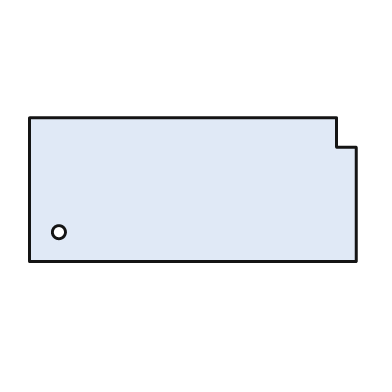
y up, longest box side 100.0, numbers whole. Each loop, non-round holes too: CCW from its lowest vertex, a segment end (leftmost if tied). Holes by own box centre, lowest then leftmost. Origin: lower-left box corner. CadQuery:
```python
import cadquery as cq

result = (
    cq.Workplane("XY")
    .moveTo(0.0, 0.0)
    .lineTo(100.0, 0.0)
    .lineTo(100.0, 35.0)
    .lineTo(94.0, 35.0)
    .lineTo(94.0, 44.0)
    .lineTo(0.0, 44.0)
    .close()
    .moveTo(9.0, 9.0)
    .circle(2.0)
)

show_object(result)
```